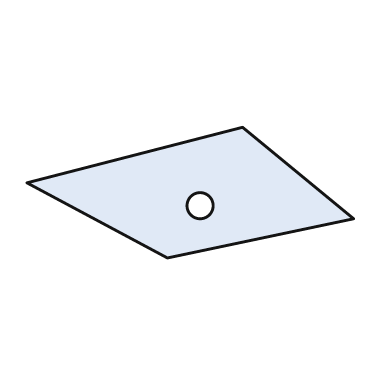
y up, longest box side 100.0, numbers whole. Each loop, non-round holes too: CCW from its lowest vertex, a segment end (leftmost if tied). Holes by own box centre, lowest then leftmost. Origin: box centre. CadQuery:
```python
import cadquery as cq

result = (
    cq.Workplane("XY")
    .moveTo(-7.0, -20.0)
    .lineTo(50.0, -8.0)
    .lineTo(16.0, 20.0)
    .lineTo(-50.0, 3.0)
    .close()
    .moveTo(3.0, -4.0)
    .circle(4.0)
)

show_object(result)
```